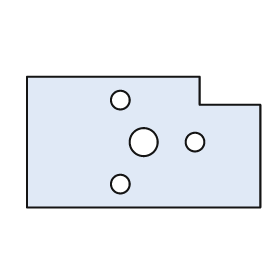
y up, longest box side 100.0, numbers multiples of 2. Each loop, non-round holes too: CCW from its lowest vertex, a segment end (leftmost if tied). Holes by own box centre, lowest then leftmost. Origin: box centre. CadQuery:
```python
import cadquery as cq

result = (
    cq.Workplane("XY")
    .moveTo(-50.0, -28.0)
    .lineTo(50.0, -28.0)
    .lineTo(50.0, 16.0)
    .lineTo(24.0, 16.0)
    .lineTo(24.0, 28.0)
    .lineTo(-50.0, 28.0)
    .close()
    .moveTo(-10.0, -18.0)
    .circle(4.0)
    .moveTo(0.0, 0.0)
    .circle(6.0)
    .moveTo(22.0, 0.0)
    .circle(4.0)
    .moveTo(-10.0, 18.0)
    .circle(4.0)
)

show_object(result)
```